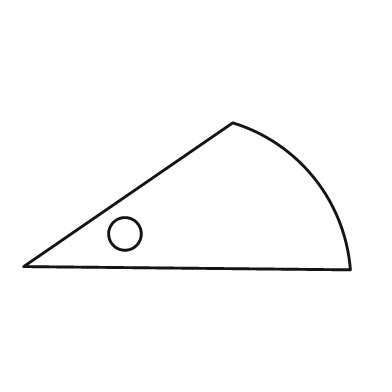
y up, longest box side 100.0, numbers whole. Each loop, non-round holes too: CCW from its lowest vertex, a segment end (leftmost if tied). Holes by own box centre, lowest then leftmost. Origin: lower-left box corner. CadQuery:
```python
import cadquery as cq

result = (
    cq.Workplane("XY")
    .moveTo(100.0, 0.0)
    .threePointArc((89.0, 28.0), (64.0, 45.0))
    .lineTo(0.0, 1.0)
    .close()
    .moveTo(31.0, 11.0)
    .circle(5.0)
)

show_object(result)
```